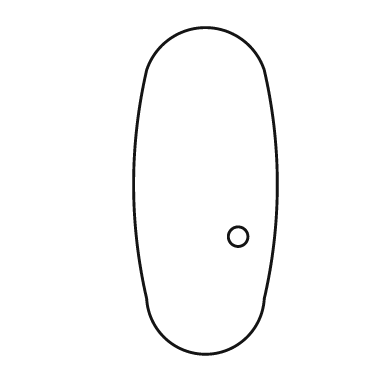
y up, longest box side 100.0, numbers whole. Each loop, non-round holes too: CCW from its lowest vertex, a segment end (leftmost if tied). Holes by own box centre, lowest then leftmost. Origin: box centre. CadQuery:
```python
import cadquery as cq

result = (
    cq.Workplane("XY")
    .moveTo(-18.0, -33.0)
    .threePointArc((0.0, -50.0), (18.0, -33.0))
    .threePointArc((22.0, 2.0), (18.0, 37.0))
    .threePointArc((0.0, 50.0), (-18.0, 37.0))
    .threePointArc((-22.0, 2.0), (-18.0, -33.0))
    .close()
    .moveTo(10.0, -14.0)
    .circle(3.0)
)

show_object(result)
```